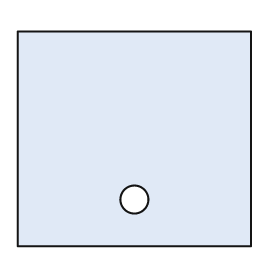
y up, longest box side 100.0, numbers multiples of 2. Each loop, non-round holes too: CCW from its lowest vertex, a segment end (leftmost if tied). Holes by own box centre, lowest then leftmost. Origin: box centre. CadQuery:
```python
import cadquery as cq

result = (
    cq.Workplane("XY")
    .moveTo(-50.0, -46.0)
    .lineTo(50.0, -46.0)
    .lineTo(50.0, 46.0)
    .lineTo(-50.0, 46.0)
    .close()
    .moveTo(0.0, -26.0)
    .circle(6.0)
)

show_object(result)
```